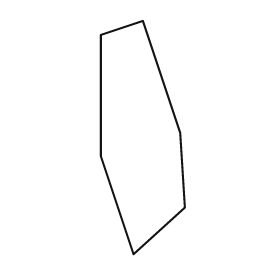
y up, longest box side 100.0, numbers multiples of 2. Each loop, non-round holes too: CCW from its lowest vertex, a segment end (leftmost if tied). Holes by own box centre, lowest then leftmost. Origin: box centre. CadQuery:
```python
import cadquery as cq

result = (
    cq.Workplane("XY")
    .moveTo(-4.0, -50.0)
    .lineTo(18.0, -30.0)
    .lineTo(16.0, 2.0)
    .lineTo(0.0, 50.0)
    .lineTo(-18.0, 44.0)
    .lineTo(-18.0, -8.0)
    .close()
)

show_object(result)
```